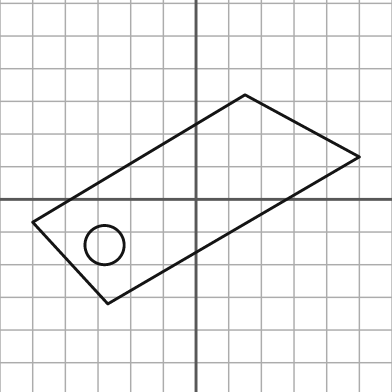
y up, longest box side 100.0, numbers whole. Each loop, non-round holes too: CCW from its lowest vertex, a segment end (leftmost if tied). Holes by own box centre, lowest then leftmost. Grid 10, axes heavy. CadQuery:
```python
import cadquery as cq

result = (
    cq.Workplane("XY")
    .moveTo(-27.0, -32.0)
    .lineTo(50.0, 13.0)
    .lineTo(15.0, 32.0)
    .lineTo(-50.0, -7.0)
    .close()
    .moveTo(-28.0, -14.0)
    .circle(6.0)
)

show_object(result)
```